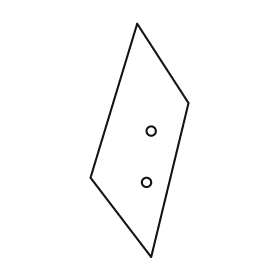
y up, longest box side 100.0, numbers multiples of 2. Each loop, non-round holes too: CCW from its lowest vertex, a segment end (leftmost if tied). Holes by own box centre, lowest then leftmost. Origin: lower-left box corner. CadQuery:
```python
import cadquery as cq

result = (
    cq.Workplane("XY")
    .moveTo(26.0, 0.0)
    .lineTo(42.0, 66.0)
    .lineTo(20.0, 100.0)
    .lineTo(0.0, 34.0)
    .close()
    .moveTo(24.0, 32.0)
    .circle(2.0)
    .moveTo(26.0, 54.0)
    .circle(2.0)
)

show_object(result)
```